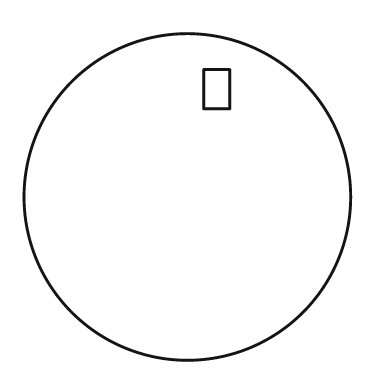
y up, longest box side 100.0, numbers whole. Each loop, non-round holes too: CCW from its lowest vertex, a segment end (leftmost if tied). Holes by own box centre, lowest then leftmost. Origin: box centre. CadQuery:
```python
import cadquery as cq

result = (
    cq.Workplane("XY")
    .moveTo(0.0, 0.0)
    .circle(50.0)
    .moveTo(5.0, 27.0)
    .lineTo(13.0, 27.0)
    .lineTo(13.0, 39.0)
    .lineTo(5.0, 39.0)
    .close()
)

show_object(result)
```